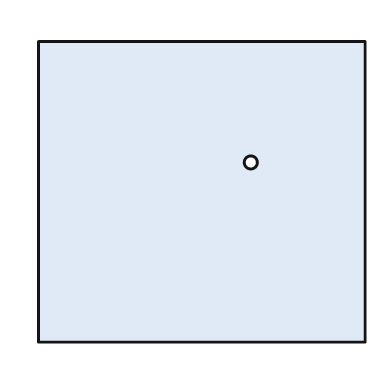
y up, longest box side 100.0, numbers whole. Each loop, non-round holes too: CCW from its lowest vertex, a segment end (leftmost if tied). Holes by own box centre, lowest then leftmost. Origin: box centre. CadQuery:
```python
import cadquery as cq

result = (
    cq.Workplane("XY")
    .moveTo(-50.0, -46.0)
    .lineTo(50.0, -46.0)
    .lineTo(50.0, 46.0)
    .lineTo(-50.0, 46.0)
    .close()
    .moveTo(15.0, 9.0)
    .circle(2.0)
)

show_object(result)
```